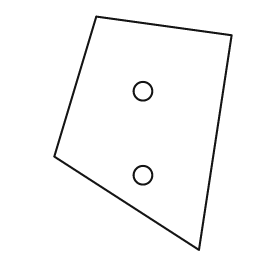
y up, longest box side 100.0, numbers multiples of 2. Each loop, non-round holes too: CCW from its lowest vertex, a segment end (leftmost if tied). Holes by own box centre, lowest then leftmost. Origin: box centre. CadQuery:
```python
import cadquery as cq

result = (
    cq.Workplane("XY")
    .moveTo(24.0, -50.0)
    .lineTo(38.0, 42.0)
    .lineTo(-20.0, 50.0)
    .lineTo(-38.0, -10.0)
    .close()
    .moveTo(0.0, -18.0)
    .circle(4.0)
    .moveTo(0.0, 18.0)
    .circle(4.0)
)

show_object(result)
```